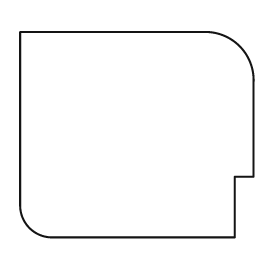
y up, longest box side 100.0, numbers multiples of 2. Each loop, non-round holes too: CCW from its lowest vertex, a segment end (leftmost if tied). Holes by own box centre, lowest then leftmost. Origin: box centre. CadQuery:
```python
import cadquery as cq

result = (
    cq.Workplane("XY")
    .moveTo(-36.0, -44.0)
    .lineTo(42.0, -44.0)
    .lineTo(42.0, -18.0)
    .lineTo(50.0, -18.0)
    .lineTo(50.0, 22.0)
    .threePointArc((44.0, 38.0), (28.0, 44.0))
    .lineTo(-50.0, 44.0)
    .lineTo(-50.0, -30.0)
    .threePointArc((-46.0, -40.0), (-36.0, -44.0))
    .close()
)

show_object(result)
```